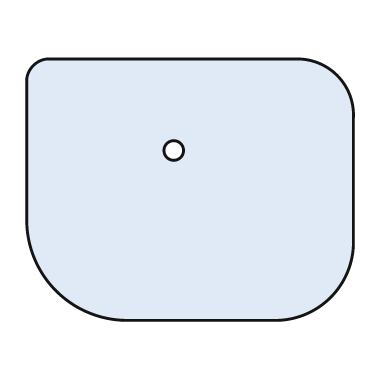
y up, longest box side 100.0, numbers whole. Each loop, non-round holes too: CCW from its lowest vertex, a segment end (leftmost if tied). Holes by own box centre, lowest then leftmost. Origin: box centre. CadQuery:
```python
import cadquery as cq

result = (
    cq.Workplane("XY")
    .moveTo(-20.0, -40.0)
    .lineTo(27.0, -40.0)
    .threePointArc((43.0, -33.0), (50.0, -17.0))
    .lineTo(50.0, 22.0)
    .threePointArc((45.0, 35.0), (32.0, 40.0))
    .lineTo(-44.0, 40.0)
    .threePointArc((-48.0, 38.0), (-50.0, 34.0))
    .lineTo(-50.0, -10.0)
    .threePointArc((-41.0, -31.0), (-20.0, -40.0))
    .close()
    .moveTo(-5.0, 12.0)
    .circle(3.0)
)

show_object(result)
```